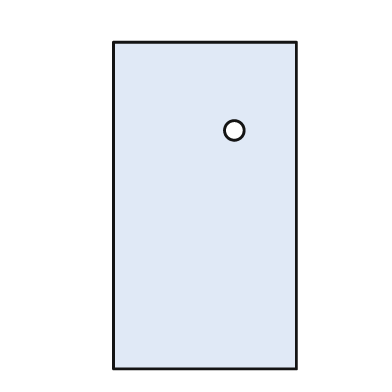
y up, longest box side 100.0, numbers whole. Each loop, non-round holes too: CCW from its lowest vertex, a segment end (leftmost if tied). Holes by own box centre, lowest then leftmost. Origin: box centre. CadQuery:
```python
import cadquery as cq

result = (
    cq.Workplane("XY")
    .moveTo(-28.0, -50.0)
    .lineTo(28.0, -50.0)
    .lineTo(28.0, 50.0)
    .lineTo(-28.0, 50.0)
    .close()
    .moveTo(9.0, 23.0)
    .circle(3.0)
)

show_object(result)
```